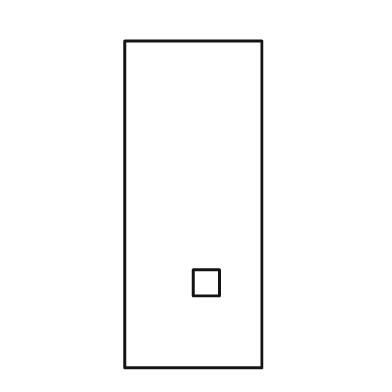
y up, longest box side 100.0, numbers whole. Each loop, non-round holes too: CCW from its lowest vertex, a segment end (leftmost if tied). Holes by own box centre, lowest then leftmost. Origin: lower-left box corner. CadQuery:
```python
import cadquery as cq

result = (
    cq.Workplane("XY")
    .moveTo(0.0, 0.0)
    .lineTo(42.0, 0.0)
    .lineTo(42.0, 100.0)
    .lineTo(0.0, 100.0)
    .close()
    .moveTo(21.0, 22.0)
    .lineTo(29.0, 22.0)
    .lineTo(29.0, 30.0)
    .lineTo(21.0, 30.0)
    .close()
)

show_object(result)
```